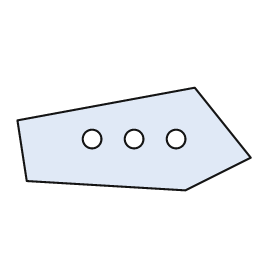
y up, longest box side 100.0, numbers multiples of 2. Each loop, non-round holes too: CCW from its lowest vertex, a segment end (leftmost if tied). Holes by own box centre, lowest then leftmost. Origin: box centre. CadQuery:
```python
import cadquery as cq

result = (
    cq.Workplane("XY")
    .moveTo(22.0, -22.0)
    .lineTo(50.0, -8.0)
    .lineTo(26.0, 22.0)
    .lineTo(-50.0, 8.0)
    .lineTo(-46.0, -18.0)
    .close()
    .moveTo(-18.0, 0.0)
    .circle(4.0)
    .moveTo(0.0, 0.0)
    .circle(4.0)
    .moveTo(18.0, 0.0)
    .circle(4.0)
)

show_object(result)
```